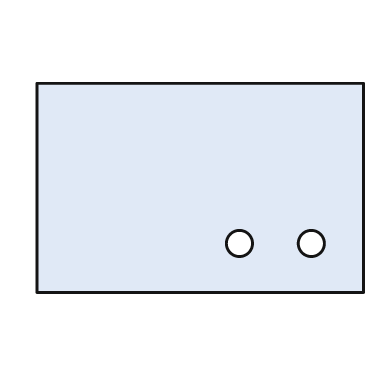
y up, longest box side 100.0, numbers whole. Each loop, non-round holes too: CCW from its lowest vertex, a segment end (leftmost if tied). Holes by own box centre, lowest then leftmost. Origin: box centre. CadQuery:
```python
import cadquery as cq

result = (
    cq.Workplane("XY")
    .moveTo(-50.0, -32.0)
    .lineTo(50.0, -32.0)
    .lineTo(50.0, 32.0)
    .lineTo(-50.0, 32.0)
    .close()
    .moveTo(12.0, -17.0)
    .circle(4.0)
    .moveTo(34.0, -17.0)
    .circle(4.0)
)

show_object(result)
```